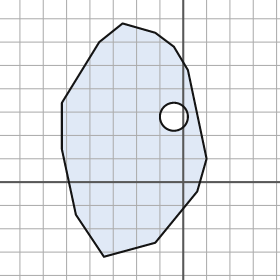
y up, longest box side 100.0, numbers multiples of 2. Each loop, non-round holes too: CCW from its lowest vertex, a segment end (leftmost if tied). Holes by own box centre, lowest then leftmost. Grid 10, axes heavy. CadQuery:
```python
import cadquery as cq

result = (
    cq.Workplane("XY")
    .moveTo(-34.0, -32.0)
    .lineTo(-12.0, -26.0)
    .lineTo(6.0, -4.0)
    .lineTo(10.0, 10.0)
    .lineTo(2.0, 48.0)
    .lineTo(-4.0, 58.0)
    .lineTo(-12.0, 64.0)
    .lineTo(-26.0, 68.0)
    .lineTo(-36.0, 60.0)
    .lineTo(-52.0, 34.0)
    .lineTo(-52.0, 14.0)
    .lineTo(-46.0, -14.0)
    .close()
    .moveTo(-4.0, 28.0)
    .circle(6.0)
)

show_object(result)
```